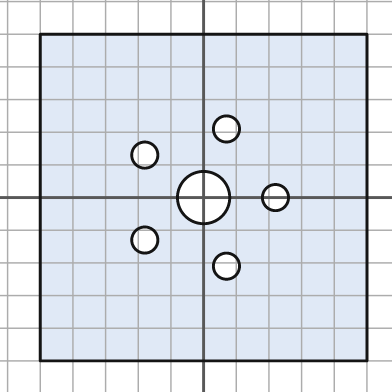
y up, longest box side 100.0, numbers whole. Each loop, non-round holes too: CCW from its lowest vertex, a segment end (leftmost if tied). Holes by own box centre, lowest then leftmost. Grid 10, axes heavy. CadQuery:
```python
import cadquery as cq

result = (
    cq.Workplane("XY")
    .moveTo(-50.0, -50.0)
    .lineTo(50.0, -50.0)
    .lineTo(50.0, 50.0)
    .lineTo(-50.0, 50.0)
    .close()
    .moveTo(7.0, -21.0)
    .circle(4.0)
    .moveTo(-18.0, -13.0)
    .circle(4.0)
    .moveTo(0.0, 0.0)
    .circle(8.0)
    .moveTo(22.0, 0.0)
    .circle(4.0)
    .moveTo(-18.0, 13.0)
    .circle(4.0)
    .moveTo(7.0, 21.0)
    .circle(4.0)
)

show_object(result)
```